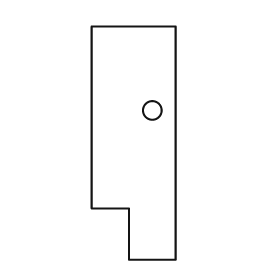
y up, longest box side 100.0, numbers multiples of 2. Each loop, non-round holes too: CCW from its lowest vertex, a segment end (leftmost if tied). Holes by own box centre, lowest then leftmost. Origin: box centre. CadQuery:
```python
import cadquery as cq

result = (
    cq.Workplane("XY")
    .moveTo(-2.0, -50.0)
    .lineTo(18.0, -50.0)
    .lineTo(18.0, 50.0)
    .lineTo(-18.0, 50.0)
    .lineTo(-18.0, -28.0)
    .lineTo(-2.0, -28.0)
    .close()
    .moveTo(8.0, 14.0)
    .circle(4.0)
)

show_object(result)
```